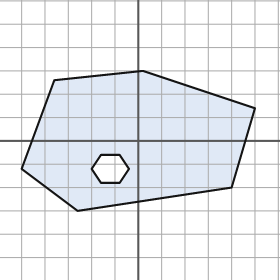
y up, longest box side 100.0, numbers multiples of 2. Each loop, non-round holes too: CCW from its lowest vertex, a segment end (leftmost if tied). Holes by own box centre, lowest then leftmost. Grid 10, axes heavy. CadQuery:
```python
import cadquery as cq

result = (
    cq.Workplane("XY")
    .moveTo(-26.0, -30.0)
    .lineTo(40.0, -20.0)
    .lineTo(50.0, 14.0)
    .lineTo(2.0, 30.0)
    .lineTo(-36.0, 26.0)
    .lineTo(-50.0, -12.0)
    .close()
    .moveTo(-16.0, -18.0)
    .lineTo(-8.0, -18.0)
    .lineTo(-4.0, -12.0)
    .lineTo(-8.0, -6.0)
    .lineTo(-16.0, -6.0)
    .lineTo(-20.0, -12.0)
    .close()
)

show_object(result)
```